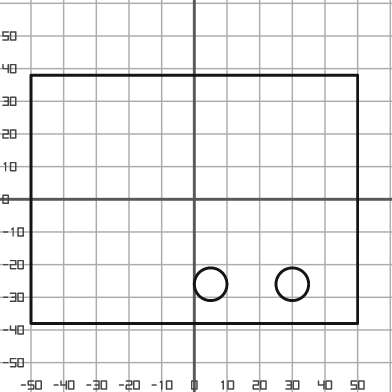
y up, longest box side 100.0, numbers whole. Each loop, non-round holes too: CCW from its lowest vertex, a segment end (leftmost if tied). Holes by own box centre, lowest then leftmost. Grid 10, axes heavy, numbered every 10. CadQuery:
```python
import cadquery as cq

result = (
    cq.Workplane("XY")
    .moveTo(-50.0, -38.0)
    .lineTo(50.0, -38.0)
    .lineTo(50.0, 38.0)
    .lineTo(-50.0, 38.0)
    .close()
    .moveTo(5.0, -26.0)
    .circle(5.0)
    .moveTo(30.0, -26.0)
    .circle(5.0)
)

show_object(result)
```